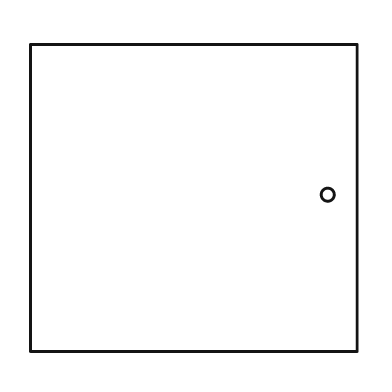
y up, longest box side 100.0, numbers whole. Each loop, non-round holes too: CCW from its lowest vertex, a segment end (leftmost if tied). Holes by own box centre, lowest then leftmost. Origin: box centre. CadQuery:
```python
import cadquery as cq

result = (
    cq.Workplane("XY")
    .moveTo(-50.0, -47.0)
    .lineTo(50.0, -47.0)
    .lineTo(50.0, 47.0)
    .lineTo(-50.0, 47.0)
    .close()
    .moveTo(41.0, 1.0)
    .circle(2.0)
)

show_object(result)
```